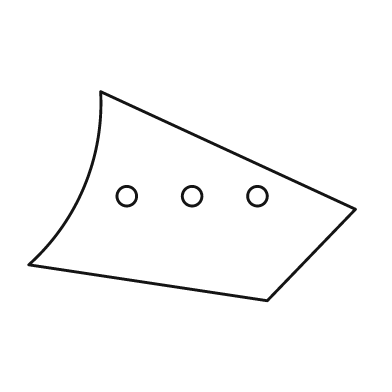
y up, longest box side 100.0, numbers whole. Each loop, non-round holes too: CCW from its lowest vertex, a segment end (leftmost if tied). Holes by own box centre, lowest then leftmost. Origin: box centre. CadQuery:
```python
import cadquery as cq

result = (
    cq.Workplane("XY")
    .moveTo(23.0, -32.0)
    .lineTo(50.0, -4.0)
    .lineTo(-28.0, 32.0)
    .threePointArc((-33.0, 3.0), (-50.0, -21.0))
    .close()
    .moveTo(-20.0, 0.0)
    .circle(3.0)
    .moveTo(0.0, 0.0)
    .circle(3.0)
    .moveTo(20.0, 0.0)
    .circle(3.0)
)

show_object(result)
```